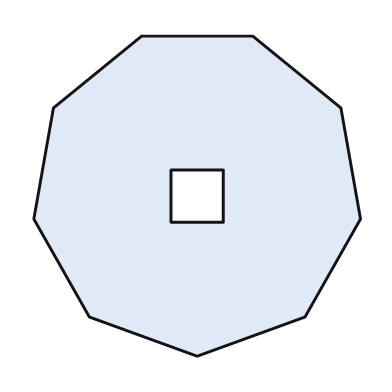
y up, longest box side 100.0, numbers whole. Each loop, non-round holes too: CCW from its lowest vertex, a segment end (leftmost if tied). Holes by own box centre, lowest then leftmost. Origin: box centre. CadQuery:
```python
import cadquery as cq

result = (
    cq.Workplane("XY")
    .moveTo(0.0, -49.0)
    .lineTo(33.0, -37.0)
    .lineTo(50.0, -7.0)
    .lineTo(44.0, 27.0)
    .lineTo(17.0, 49.0)
    .lineTo(-17.0, 49.0)
    .lineTo(-44.0, 27.0)
    .lineTo(-50.0, -7.0)
    .lineTo(-33.0, -37.0)
    .close()
    .moveTo(-8.0, -8.0)
    .lineTo(8.0, -8.0)
    .lineTo(8.0, 8.0)
    .lineTo(-8.0, 8.0)
    .close()
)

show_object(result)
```